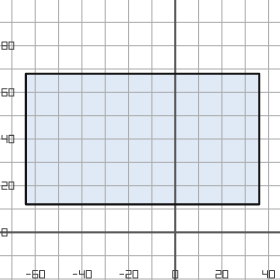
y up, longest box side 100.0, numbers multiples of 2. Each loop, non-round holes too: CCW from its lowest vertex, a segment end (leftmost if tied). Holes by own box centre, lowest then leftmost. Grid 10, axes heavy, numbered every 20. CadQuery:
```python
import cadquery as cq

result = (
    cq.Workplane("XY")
    .moveTo(-64.0, 12.0)
    .lineTo(36.0, 12.0)
    .lineTo(36.0, 68.0)
    .lineTo(-64.0, 68.0)
    .close()
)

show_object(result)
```